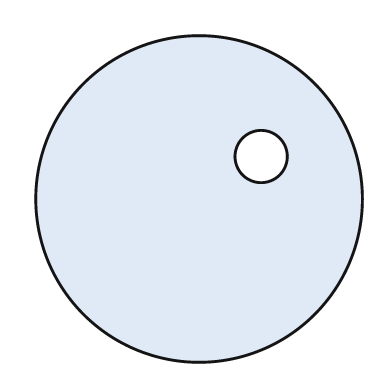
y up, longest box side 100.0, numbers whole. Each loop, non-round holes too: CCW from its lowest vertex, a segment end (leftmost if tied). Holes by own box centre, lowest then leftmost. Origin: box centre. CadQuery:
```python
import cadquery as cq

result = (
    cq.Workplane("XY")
    .moveTo(0.0, 0.0)
    .circle(50.0)
    .moveTo(19.0, 13.0)
    .circle(8.0)
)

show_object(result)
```